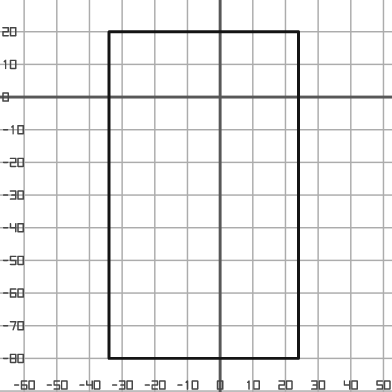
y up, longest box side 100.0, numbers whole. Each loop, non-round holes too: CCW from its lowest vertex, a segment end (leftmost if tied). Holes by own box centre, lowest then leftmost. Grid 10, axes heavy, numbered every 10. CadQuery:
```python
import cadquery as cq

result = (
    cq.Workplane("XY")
    .moveTo(-34.0, -80.0)
    .lineTo(24.0, -80.0)
    .lineTo(24.0, 20.0)
    .lineTo(-34.0, 20.0)
    .close()
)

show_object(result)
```